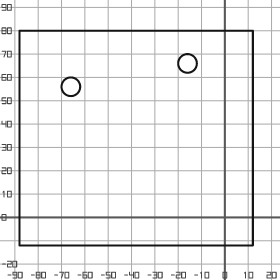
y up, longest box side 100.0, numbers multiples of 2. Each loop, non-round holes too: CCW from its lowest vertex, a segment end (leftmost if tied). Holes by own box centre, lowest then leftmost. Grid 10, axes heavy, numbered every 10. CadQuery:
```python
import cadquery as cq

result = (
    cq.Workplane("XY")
    .moveTo(-88.0, -12.0)
    .lineTo(12.0, -12.0)
    .lineTo(12.0, 80.0)
    .lineTo(-88.0, 80.0)
    .close()
    .moveTo(-66.0, 56.0)
    .circle(4.0)
    .moveTo(-16.0, 66.0)
    .circle(4.0)
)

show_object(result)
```